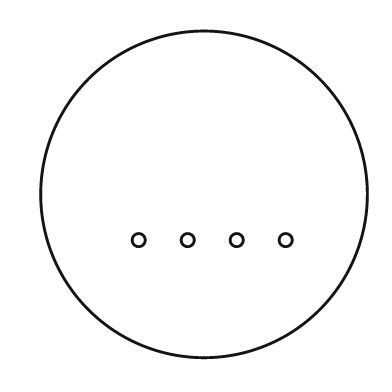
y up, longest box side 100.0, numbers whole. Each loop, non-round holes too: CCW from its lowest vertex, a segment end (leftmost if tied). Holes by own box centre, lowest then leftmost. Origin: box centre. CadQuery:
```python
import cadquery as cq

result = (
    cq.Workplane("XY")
    .moveTo(0.0, 0.0)
    .circle(50.0)
    .moveTo(-20.0, -14.0)
    .circle(2.0)
    .moveTo(-5.0, -14.0)
    .circle(2.0)
    .moveTo(10.0, -14.0)
    .circle(2.0)
    .moveTo(25.0, -14.0)
    .circle(2.0)
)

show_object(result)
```